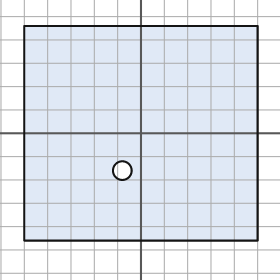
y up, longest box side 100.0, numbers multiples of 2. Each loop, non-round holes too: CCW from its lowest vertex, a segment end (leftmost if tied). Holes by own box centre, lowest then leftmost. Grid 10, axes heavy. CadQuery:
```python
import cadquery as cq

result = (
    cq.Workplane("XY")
    .moveTo(-50.0, -46.0)
    .lineTo(50.0, -46.0)
    .lineTo(50.0, 46.0)
    .lineTo(-50.0, 46.0)
    .close()
    .moveTo(-8.0, -16.0)
    .circle(4.0)
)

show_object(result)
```